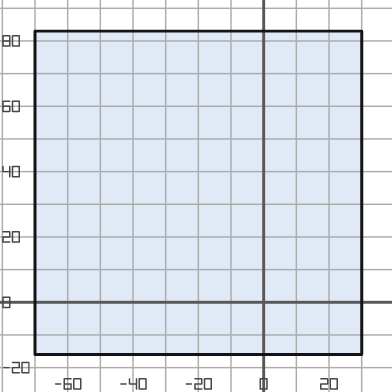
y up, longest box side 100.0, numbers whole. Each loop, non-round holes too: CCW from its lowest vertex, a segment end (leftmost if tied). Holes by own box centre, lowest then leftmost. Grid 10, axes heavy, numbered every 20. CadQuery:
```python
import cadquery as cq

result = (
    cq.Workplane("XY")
    .moveTo(-70.0, -16.0)
    .lineTo(30.0, -16.0)
    .lineTo(30.0, 83.0)
    .lineTo(-70.0, 83.0)
    .close()
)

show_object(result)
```